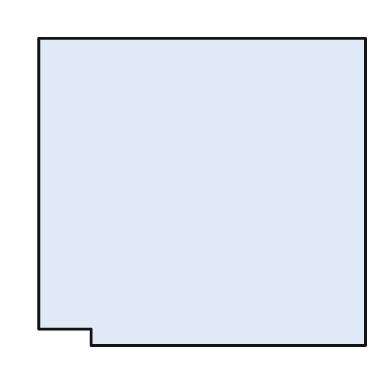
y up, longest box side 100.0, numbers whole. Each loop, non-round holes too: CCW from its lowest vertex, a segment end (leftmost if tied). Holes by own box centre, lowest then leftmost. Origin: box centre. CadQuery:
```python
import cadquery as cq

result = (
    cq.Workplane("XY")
    .moveTo(-34.0, -47.0)
    .lineTo(50.0, -47.0)
    .lineTo(50.0, 47.0)
    .lineTo(-50.0, 47.0)
    .lineTo(-50.0, -42.0)
    .lineTo(-34.0, -42.0)
    .close()
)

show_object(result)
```